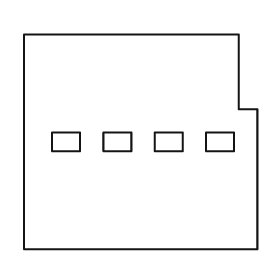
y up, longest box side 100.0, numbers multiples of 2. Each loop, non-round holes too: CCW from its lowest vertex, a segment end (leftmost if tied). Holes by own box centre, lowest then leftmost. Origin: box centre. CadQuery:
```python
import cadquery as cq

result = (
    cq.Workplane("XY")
    .moveTo(-50.0, -46.0)
    .lineTo(50.0, -46.0)
    .lineTo(50.0, 14.0)
    .lineTo(42.0, 14.0)
    .lineTo(42.0, 46.0)
    .lineTo(-50.0, 46.0)
    .close()
    .moveTo(-38.0, -4.0)
    .lineTo(-26.0, -4.0)
    .lineTo(-26.0, 4.0)
    .lineTo(-38.0, 4.0)
    .close()
    .moveTo(-16.0, -4.0)
    .lineTo(-4.0, -4.0)
    .lineTo(-4.0, 4.0)
    .lineTo(-16.0, 4.0)
    .close()
    .moveTo(6.0, -4.0)
    .lineTo(18.0, -4.0)
    .lineTo(18.0, 4.0)
    .lineTo(6.0, 4.0)
    .close()
    .moveTo(28.0, -4.0)
    .lineTo(40.0, -4.0)
    .lineTo(40.0, 4.0)
    .lineTo(28.0, 4.0)
    .close()
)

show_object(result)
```